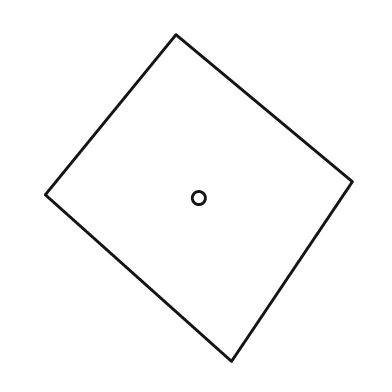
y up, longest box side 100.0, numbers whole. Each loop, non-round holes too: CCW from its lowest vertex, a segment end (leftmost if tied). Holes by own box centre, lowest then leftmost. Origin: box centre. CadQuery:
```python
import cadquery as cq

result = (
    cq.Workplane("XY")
    .moveTo(10.0, -50.0)
    .lineTo(47.0, 5.0)
    .lineTo(-7.0, 50.0)
    .lineTo(-47.0, 1.0)
    .close()
    .moveTo(0.0, 0.0)
    .circle(2.0)
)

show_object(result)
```